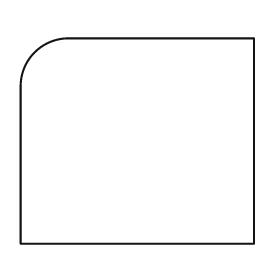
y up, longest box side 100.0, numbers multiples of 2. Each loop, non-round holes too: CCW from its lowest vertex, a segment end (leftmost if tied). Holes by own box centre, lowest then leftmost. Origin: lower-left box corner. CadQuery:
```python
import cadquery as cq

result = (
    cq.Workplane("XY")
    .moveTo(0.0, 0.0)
    .lineTo(100.0, 0.0)
    .lineTo(100.0, 88.0)
    .lineTo(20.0, 88.0)
    .threePointArc((6.0, 82.0), (0.0, 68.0))
    .close()
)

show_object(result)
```